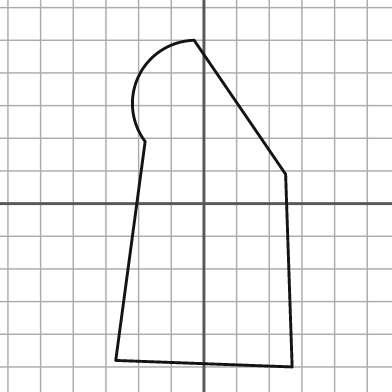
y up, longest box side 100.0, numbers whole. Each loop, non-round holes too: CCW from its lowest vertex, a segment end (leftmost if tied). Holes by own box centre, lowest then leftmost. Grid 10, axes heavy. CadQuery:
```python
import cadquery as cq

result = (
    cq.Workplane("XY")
    .moveTo(27.0, -50.0)
    .lineTo(25.0, 9.0)
    .lineTo(-3.0, 50.0)
    .threePointArc((-20.0, 39.0), (-18.0, 19.0))
    .lineTo(-27.0, -48.0)
    .close()
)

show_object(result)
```